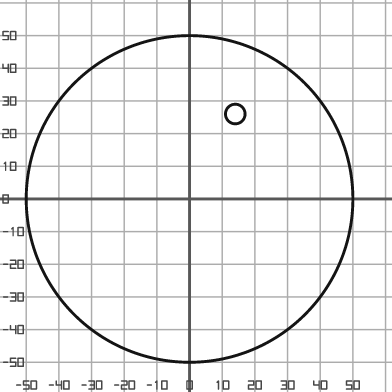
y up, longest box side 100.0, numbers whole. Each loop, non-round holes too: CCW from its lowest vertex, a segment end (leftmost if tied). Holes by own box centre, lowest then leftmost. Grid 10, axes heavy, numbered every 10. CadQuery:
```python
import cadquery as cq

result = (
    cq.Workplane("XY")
    .moveTo(0.0, 0.0)
    .circle(50.0)
    .moveTo(14.0, 26.0)
    .circle(3.0)
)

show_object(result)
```